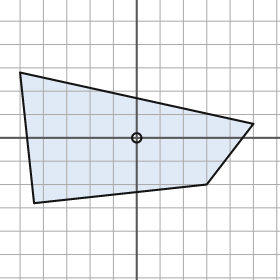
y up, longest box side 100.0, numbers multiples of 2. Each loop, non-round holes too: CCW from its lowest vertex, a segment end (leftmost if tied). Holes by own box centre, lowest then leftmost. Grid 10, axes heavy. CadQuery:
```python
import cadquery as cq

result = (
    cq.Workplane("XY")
    .moveTo(-44.0, -28.0)
    .lineTo(30.0, -20.0)
    .lineTo(50.0, 6.0)
    .lineTo(-50.0, 28.0)
    .close()
    .moveTo(0.0, 0.0)
    .circle(2.0)
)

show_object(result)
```